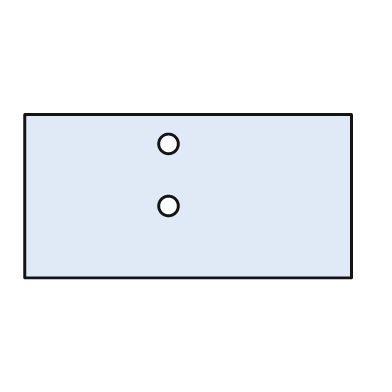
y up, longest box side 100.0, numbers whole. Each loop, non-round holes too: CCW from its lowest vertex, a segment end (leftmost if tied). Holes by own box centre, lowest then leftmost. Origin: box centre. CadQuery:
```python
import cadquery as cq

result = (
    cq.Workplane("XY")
    .moveTo(-50.0, -25.0)
    .lineTo(50.0, -25.0)
    .lineTo(50.0, 25.0)
    .lineTo(-50.0, 25.0)
    .close()
    .moveTo(-6.0, -3.0)
    .circle(3.0)
    .moveTo(-6.0, 16.0)
    .circle(3.0)
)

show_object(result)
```